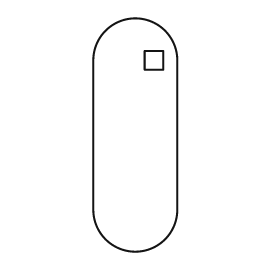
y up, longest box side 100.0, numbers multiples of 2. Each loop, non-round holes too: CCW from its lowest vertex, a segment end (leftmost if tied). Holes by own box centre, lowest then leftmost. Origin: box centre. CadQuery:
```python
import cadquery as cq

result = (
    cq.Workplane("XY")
    .moveTo(-18.0, -32.0)
    .threePointArc((0.0, -50.0), (18.0, -32.0))
    .lineTo(18.0, 32.0)
    .threePointArc((0.0, 50.0), (-18.0, 32.0))
    .close()
    .moveTo(4.0, 28.0)
    .lineTo(12.0, 28.0)
    .lineTo(12.0, 36.0)
    .lineTo(4.0, 36.0)
    .close()
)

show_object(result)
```